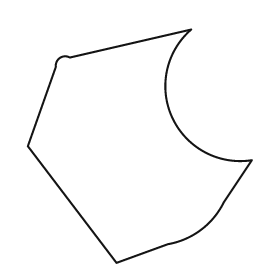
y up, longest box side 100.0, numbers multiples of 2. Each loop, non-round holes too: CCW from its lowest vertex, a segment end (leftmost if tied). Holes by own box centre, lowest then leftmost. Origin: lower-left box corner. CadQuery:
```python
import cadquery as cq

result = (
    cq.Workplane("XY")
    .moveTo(38.0, 0.0)
    .lineTo(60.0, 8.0)
    .threePointArc((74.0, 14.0), (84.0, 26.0))
    .lineTo(96.0, 44.0)
    .threePointArc((62.0, 62.0), (70.0, 100.0))
    .lineTo(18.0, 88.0)
    .threePointArc((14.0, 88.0), (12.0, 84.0))
    .lineTo(0.0, 50.0)
    .close()
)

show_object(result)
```